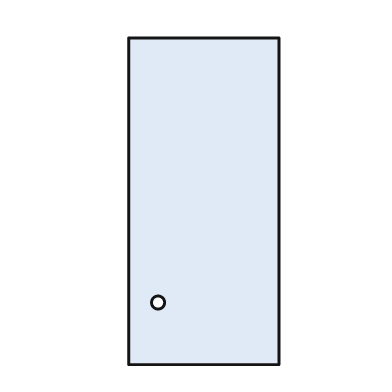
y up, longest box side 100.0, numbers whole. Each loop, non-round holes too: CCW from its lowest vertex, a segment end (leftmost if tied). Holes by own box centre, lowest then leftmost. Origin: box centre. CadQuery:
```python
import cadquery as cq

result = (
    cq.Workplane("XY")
    .moveTo(-23.0, -50.0)
    .lineTo(23.0, -50.0)
    .lineTo(23.0, 50.0)
    .lineTo(-23.0, 50.0)
    .close()
    .moveTo(-14.0, -31.0)
    .circle(2.0)
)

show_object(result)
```